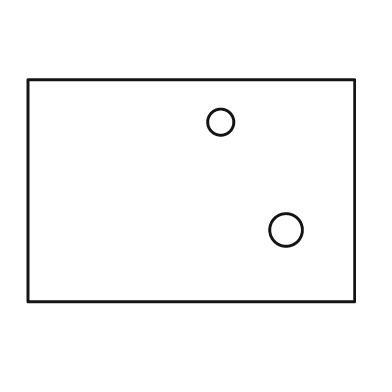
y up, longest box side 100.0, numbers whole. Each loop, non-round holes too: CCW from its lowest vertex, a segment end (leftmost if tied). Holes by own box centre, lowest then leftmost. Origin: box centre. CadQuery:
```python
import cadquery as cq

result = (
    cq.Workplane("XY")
    .moveTo(-50.0, -34.0)
    .lineTo(50.0, -34.0)
    .lineTo(50.0, 34.0)
    .lineTo(-50.0, 34.0)
    .close()
    .moveTo(29.0, -12.0)
    .circle(5.0)
    .moveTo(9.0, 21.0)
    .circle(4.0)
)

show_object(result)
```